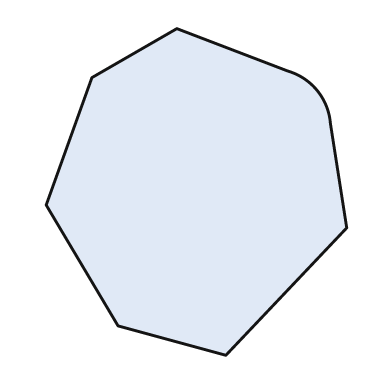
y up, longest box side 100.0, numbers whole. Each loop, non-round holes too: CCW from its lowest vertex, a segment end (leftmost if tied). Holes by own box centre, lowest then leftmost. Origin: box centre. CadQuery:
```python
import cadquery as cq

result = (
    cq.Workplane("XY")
    .moveTo(9.0, -50.0)
    .lineTo(46.0, -11.0)
    .lineTo(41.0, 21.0)
    .threePointArc((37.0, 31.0), (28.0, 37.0))
    .lineTo(-6.0, 50.0)
    .lineTo(-32.0, 35.0)
    .lineTo(-46.0, -4.0)
    .lineTo(-24.0, -41.0)
    .close()
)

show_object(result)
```